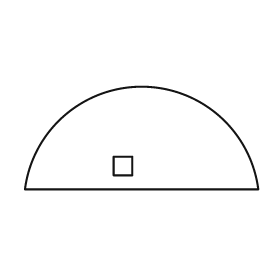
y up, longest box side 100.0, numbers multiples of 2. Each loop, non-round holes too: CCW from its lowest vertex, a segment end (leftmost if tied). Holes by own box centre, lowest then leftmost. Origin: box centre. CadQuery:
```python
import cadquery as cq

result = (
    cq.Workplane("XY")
    .moveTo(-50.0, -22.0)
    .lineTo(50.0, -22.0)
    .threePointArc((0.0, 22.0), (-50.0, -22.0))
    .close()
    .moveTo(-12.0, -16.0)
    .lineTo(-4.0, -16.0)
    .lineTo(-4.0, -8.0)
    .lineTo(-12.0, -8.0)
    .close()
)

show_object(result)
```